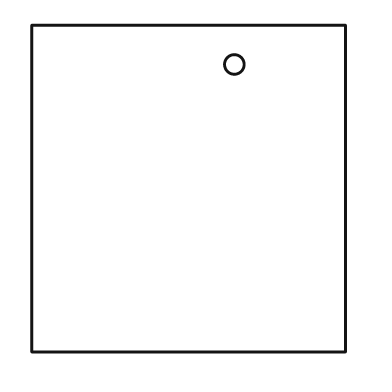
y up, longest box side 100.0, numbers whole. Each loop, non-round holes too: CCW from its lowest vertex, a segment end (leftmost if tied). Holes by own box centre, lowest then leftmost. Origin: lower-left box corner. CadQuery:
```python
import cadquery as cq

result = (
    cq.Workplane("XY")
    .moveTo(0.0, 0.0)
    .lineTo(96.0, 0.0)
    .lineTo(96.0, 100.0)
    .lineTo(0.0, 100.0)
    .close()
    .moveTo(62.0, 88.0)
    .circle(3.0)
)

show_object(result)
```